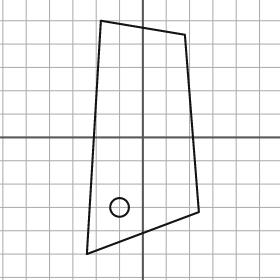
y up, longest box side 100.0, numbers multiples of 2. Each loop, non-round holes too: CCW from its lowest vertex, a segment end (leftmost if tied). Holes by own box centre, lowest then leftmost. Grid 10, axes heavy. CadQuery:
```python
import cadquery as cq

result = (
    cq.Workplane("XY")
    .moveTo(-24.0, -50.0)
    .lineTo(24.0, -32.0)
    .lineTo(18.0, 44.0)
    .lineTo(-18.0, 50.0)
    .close()
    .moveTo(-10.0, -30.0)
    .circle(4.0)
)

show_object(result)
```